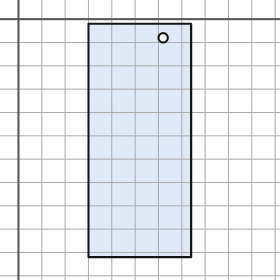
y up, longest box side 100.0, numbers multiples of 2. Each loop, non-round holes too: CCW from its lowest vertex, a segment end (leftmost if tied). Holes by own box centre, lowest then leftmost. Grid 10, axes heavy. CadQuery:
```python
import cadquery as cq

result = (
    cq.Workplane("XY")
    .moveTo(30.0, -102.0)
    .lineTo(74.0, -102.0)
    .lineTo(74.0, -2.0)
    .lineTo(30.0, -2.0)
    .close()
    .moveTo(62.0, -8.0)
    .circle(2.0)
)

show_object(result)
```